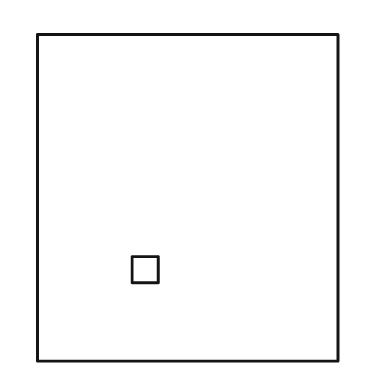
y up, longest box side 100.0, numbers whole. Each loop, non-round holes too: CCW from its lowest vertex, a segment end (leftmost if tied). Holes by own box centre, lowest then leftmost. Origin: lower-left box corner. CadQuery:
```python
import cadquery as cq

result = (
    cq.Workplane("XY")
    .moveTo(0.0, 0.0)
    .lineTo(92.0, 0.0)
    .lineTo(92.0, 100.0)
    .lineTo(0.0, 100.0)
    .close()
    .moveTo(29.0, 24.0)
    .lineTo(37.0, 24.0)
    .lineTo(37.0, 32.0)
    .lineTo(29.0, 32.0)
    .close()
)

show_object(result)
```